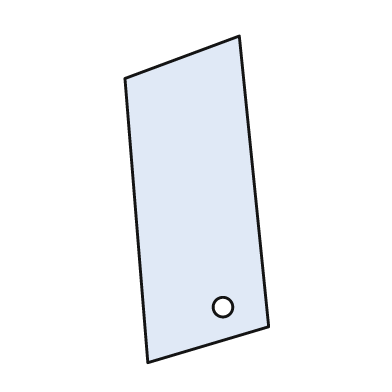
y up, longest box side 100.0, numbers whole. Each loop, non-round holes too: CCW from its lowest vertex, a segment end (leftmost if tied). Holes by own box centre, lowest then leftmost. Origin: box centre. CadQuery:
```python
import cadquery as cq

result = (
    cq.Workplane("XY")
    .moveTo(-15.0, -50.0)
    .lineTo(22.0, -39.0)
    .lineTo(13.0, 50.0)
    .lineTo(-22.0, 37.0)
    .close()
    .moveTo(8.0, -33.0)
    .circle(3.0)
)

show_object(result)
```